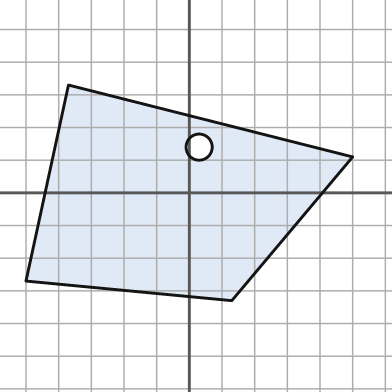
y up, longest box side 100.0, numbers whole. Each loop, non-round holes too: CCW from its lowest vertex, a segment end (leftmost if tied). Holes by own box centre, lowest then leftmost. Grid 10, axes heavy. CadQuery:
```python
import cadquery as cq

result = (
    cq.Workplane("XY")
    .moveTo(13.0, -33.0)
    .lineTo(50.0, 11.0)
    .lineTo(-37.0, 33.0)
    .lineTo(-50.0, -27.0)
    .close()
    .moveTo(3.0, 14.0)
    .circle(4.0)
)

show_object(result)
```